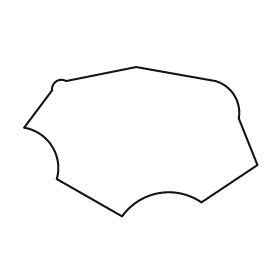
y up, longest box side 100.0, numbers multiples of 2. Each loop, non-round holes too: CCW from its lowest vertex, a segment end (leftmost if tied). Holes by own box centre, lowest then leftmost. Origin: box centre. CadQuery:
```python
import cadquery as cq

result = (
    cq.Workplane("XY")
    .moveTo(-8.0, -32.0)
    .threePointArc((8.0, -22.0), (26.0, -26.0))
    .lineTo(50.0, -10.0)
    .lineTo(42.0, 10.0)
    .threePointArc((40.0, 20.0), (32.0, 26.0))
    .lineTo(-2.0, 32.0)
    .lineTo(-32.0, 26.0)
    .threePointArc((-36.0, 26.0), (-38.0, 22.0))
    .lineTo(-50.0, 6.0)
    .threePointArc((-38.0, -2.0), (-36.0, -16.0))
    .close()
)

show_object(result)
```